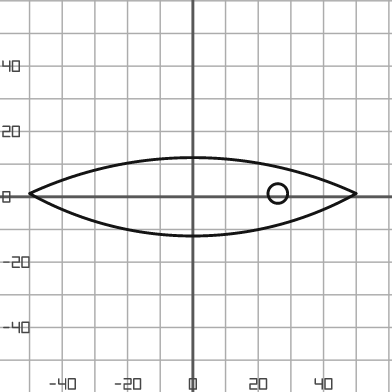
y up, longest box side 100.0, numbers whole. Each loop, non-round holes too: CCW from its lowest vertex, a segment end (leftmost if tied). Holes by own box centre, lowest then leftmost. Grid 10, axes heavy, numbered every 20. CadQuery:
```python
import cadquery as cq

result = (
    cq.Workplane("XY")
    .moveTo(-50.0, 1.0)
    .threePointArc((0.0, -12.0), (50.0, 1.0))
    .threePointArc((0.0, 12.0), (-50.0, 1.0))
    .close()
    .moveTo(26.0, 1.0)
    .circle(3.0)
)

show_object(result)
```